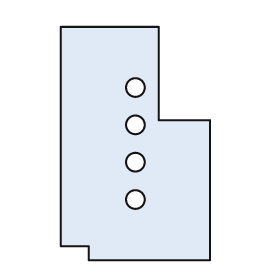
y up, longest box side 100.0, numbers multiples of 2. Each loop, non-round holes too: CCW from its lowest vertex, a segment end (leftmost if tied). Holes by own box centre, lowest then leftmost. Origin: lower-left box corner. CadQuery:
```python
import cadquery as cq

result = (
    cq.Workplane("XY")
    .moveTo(12.0, 0.0)
    .lineTo(64.0, 0.0)
    .lineTo(64.0, 60.0)
    .lineTo(42.0, 60.0)
    .lineTo(42.0, 100.0)
    .lineTo(0.0, 100.0)
    .lineTo(0.0, 6.0)
    .lineTo(12.0, 6.0)
    .close()
    .moveTo(32.0, 26.0)
    .circle(4.0)
    .moveTo(32.0, 42.0)
    .circle(4.0)
    .moveTo(32.0, 58.0)
    .circle(4.0)
    .moveTo(32.0, 74.0)
    .circle(4.0)
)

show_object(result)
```